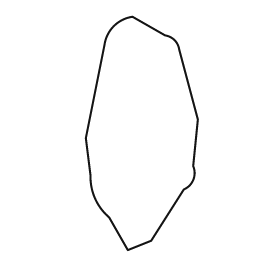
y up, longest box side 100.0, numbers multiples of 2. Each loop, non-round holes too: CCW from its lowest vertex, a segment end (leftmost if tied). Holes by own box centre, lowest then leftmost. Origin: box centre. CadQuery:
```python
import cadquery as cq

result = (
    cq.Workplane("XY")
    .moveTo(-6.0, -50.0)
    .lineTo(4.0, -46.0)
    .lineTo(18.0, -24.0)
    .threePointArc((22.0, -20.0), (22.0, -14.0))
    .lineTo(24.0, 6.0)
    .lineTo(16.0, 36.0)
    .threePointArc((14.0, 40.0), (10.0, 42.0))
    .lineTo(-4.0, 50.0)
    .threePointArc((-12.0, 46.0), (-16.0, 38.0))
    .lineTo(-24.0, -2.0)
    .lineTo(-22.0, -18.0)
    .threePointArc((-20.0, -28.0), (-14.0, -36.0))
    .close()
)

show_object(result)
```